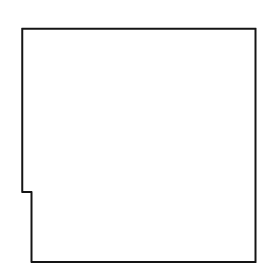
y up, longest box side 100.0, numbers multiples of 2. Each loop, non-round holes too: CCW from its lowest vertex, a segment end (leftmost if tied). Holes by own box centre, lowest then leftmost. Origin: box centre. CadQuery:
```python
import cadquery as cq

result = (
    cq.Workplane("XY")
    .moveTo(-46.0, -50.0)
    .lineTo(50.0, -50.0)
    .lineTo(50.0, 50.0)
    .lineTo(-50.0, 50.0)
    .lineTo(-50.0, -20.0)
    .lineTo(-46.0, -20.0)
    .close()
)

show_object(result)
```